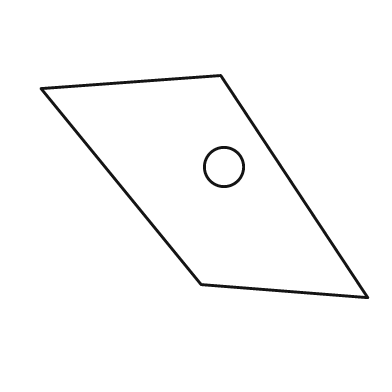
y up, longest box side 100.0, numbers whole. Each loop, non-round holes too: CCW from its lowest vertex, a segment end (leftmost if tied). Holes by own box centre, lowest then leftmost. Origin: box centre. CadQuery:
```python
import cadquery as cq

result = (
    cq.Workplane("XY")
    .moveTo(50.0, -34.0)
    .lineTo(5.0, 34.0)
    .lineTo(-50.0, 30.0)
    .lineTo(-1.0, -30.0)
    .close()
    .moveTo(6.0, 6.0)
    .circle(6.0)
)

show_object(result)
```